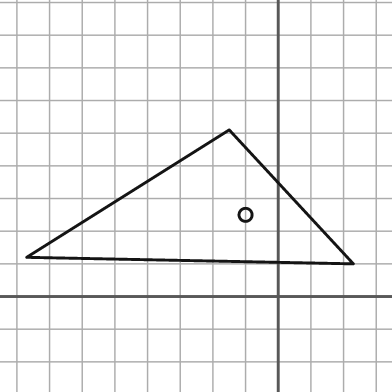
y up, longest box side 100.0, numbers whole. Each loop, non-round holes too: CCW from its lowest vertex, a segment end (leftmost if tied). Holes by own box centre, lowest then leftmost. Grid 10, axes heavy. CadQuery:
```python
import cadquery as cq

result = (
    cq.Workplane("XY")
    .moveTo(23.0, 10.0)
    .lineTo(-15.0, 51.0)
    .lineTo(-77.0, 12.0)
    .close()
    .moveTo(-10.0, 25.0)
    .circle(2.0)
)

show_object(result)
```